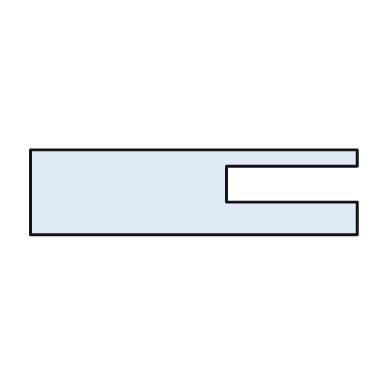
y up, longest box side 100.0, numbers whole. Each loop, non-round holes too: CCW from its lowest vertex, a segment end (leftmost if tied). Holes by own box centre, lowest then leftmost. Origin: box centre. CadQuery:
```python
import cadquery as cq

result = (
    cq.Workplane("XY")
    .moveTo(-50.0, -13.0)
    .lineTo(50.0, -13.0)
    .lineTo(50.0, -3.0)
    .lineTo(10.0, -3.0)
    .lineTo(10.0, 8.0)
    .lineTo(50.0, 8.0)
    .lineTo(50.0, 13.0)
    .lineTo(-50.0, 13.0)
    .close()
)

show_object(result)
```